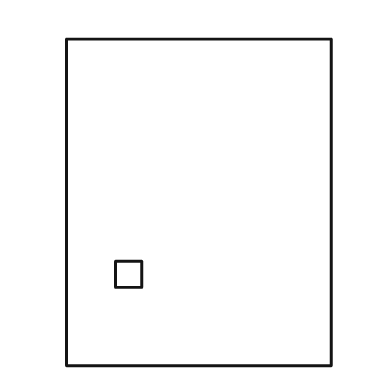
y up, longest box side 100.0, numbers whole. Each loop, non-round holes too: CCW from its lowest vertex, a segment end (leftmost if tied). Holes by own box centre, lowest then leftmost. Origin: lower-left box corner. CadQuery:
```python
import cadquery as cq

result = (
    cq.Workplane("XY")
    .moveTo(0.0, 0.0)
    .lineTo(81.0, 0.0)
    .lineTo(81.0, 100.0)
    .lineTo(0.0, 100.0)
    .close()
    .moveTo(15.0, 24.0)
    .lineTo(23.0, 24.0)
    .lineTo(23.0, 32.0)
    .lineTo(15.0, 32.0)
    .close()
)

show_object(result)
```